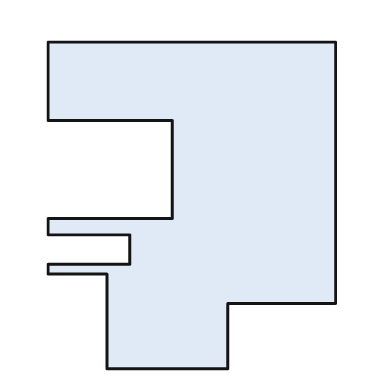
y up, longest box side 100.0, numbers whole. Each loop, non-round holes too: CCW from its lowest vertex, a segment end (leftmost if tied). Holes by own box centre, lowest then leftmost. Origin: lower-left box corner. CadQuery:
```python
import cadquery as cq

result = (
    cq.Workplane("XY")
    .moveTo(18.0, 0.0)
    .lineTo(55.0, 0.0)
    .lineTo(55.0, 20.0)
    .lineTo(88.0, 20.0)
    .lineTo(88.0, 100.0)
    .lineTo(0.0, 100.0)
    .lineTo(0.0, 76.0)
    .lineTo(38.0, 76.0)
    .lineTo(38.0, 46.0)
    .lineTo(0.0, 46.0)
    .lineTo(0.0, 41.0)
    .lineTo(25.0, 41.0)
    .lineTo(25.0, 32.0)
    .lineTo(0.0, 32.0)
    .lineTo(0.0, 29.0)
    .lineTo(18.0, 29.0)
    .close()
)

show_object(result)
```